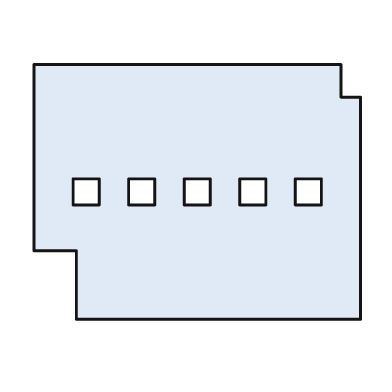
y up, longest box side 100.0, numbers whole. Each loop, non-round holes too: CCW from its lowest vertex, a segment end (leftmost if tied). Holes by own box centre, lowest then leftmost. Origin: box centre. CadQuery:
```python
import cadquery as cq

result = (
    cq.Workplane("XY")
    .moveTo(-37.0, -39.0)
    .lineTo(50.0, -39.0)
    .lineTo(50.0, 29.0)
    .lineTo(44.0, 29.0)
    .lineTo(44.0, 39.0)
    .lineTo(-50.0, 39.0)
    .lineTo(-50.0, -18.0)
    .lineTo(-37.0, -18.0)
    .close()
    .moveTo(-38.0, -4.0)
    .lineTo(-30.0, -4.0)
    .lineTo(-30.0, 4.0)
    .lineTo(-38.0, 4.0)
    .close()
    .moveTo(-21.0, -4.0)
    .lineTo(-13.0, -4.0)
    .lineTo(-13.0, 4.0)
    .lineTo(-21.0, 4.0)
    .close()
    .moveTo(-4.0, -4.0)
    .lineTo(4.0, -4.0)
    .lineTo(4.0, 4.0)
    .lineTo(-4.0, 4.0)
    .close()
    .moveTo(13.0, -4.0)
    .lineTo(21.0, -4.0)
    .lineTo(21.0, 4.0)
    .lineTo(13.0, 4.0)
    .close()
    .moveTo(30.0, -4.0)
    .lineTo(38.0, -4.0)
    .lineTo(38.0, 4.0)
    .lineTo(30.0, 4.0)
    .close()
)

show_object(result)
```